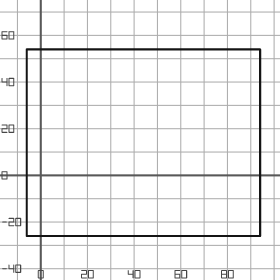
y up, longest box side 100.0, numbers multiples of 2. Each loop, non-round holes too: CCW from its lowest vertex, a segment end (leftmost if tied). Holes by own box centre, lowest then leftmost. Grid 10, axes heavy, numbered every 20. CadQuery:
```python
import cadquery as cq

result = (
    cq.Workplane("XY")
    .moveTo(-6.0, -26.0)
    .lineTo(94.0, -26.0)
    .lineTo(94.0, 54.0)
    .lineTo(-6.0, 54.0)
    .close()
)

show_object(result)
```